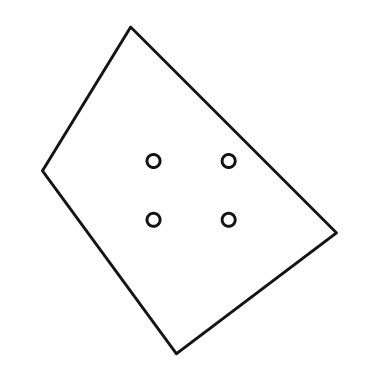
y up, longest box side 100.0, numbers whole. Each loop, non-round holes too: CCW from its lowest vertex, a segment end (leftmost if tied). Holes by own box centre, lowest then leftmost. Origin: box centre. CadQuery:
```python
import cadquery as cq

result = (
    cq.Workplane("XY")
    .moveTo(-4.0, -50.0)
    .lineTo(45.0, -13.0)
    .lineTo(-18.0, 50.0)
    .lineTo(-45.0, 6.0)
    .close()
    .moveTo(-11.0, -9.0)
    .circle(2.0)
    .moveTo(12.0, -9.0)
    .circle(2.0)
    .moveTo(-11.0, 9.0)
    .circle(2.0)
    .moveTo(12.0, 9.0)
    .circle(2.0)
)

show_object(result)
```